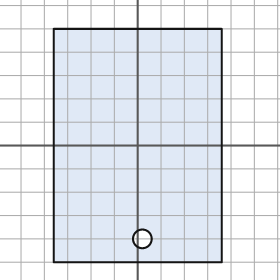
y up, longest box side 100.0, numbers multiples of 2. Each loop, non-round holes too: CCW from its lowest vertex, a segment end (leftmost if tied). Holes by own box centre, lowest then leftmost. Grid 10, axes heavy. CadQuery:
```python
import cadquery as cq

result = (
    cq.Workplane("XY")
    .moveTo(-36.0, -50.0)
    .lineTo(36.0, -50.0)
    .lineTo(36.0, 50.0)
    .lineTo(-36.0, 50.0)
    .close()
    .moveTo(2.0, -40.0)
    .circle(4.0)
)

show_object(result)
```